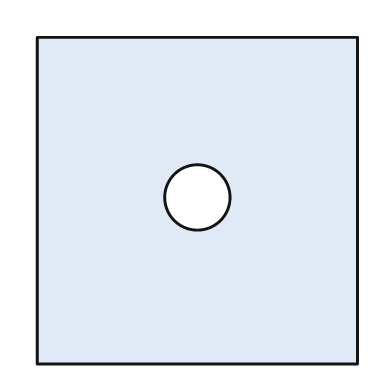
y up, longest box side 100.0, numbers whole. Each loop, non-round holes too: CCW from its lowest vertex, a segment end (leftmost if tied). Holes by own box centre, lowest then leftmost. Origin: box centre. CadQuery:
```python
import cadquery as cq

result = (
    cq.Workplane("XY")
    .moveTo(-49.0, -50.0)
    .lineTo(49.0, -50.0)
    .lineTo(49.0, 50.0)
    .lineTo(-49.0, 50.0)
    .close()
    .moveTo(0.0, 1.0)
    .circle(10.0)
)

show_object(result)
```